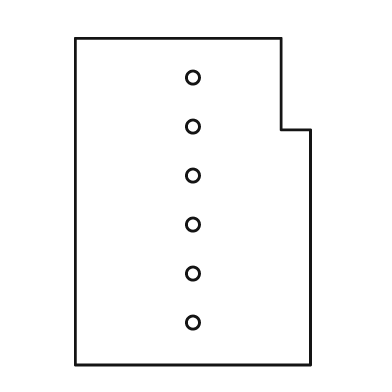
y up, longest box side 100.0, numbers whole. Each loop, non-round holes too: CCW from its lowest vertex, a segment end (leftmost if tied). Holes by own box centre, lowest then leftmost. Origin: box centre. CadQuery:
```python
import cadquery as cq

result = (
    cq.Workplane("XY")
    .moveTo(-36.0, -50.0)
    .lineTo(36.0, -50.0)
    .lineTo(36.0, 22.0)
    .lineTo(27.0, 22.0)
    .lineTo(27.0, 50.0)
    .lineTo(-36.0, 50.0)
    .close()
    .moveTo(0.0, -37.0)
    .circle(2.0)
    .moveTo(0.0, -22.0)
    .circle(2.0)
    .moveTo(0.0, -7.0)
    .circle(2.0)
    .moveTo(0.0, 8.0)
    .circle(2.0)
    .moveTo(0.0, 23.0)
    .circle(2.0)
    .moveTo(0.0, 38.0)
    .circle(2.0)
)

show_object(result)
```